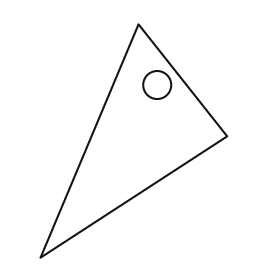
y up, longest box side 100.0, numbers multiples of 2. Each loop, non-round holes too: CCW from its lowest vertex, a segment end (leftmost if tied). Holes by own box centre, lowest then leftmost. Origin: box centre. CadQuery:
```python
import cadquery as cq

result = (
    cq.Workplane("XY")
    .moveTo(-40.0, -50.0)
    .lineTo(40.0, 2.0)
    .lineTo(2.0, 50.0)
    .close()
    .moveTo(10.0, 24.0)
    .circle(6.0)
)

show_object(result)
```